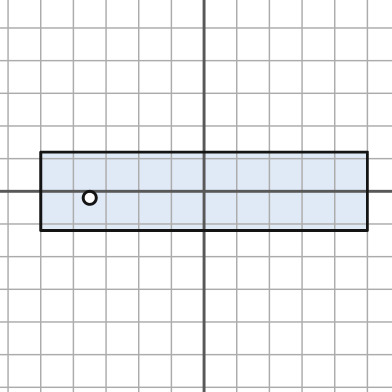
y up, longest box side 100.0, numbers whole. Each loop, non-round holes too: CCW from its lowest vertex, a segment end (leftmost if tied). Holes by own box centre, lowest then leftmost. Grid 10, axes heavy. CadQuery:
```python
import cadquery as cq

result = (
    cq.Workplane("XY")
    .moveTo(-50.0, -12.0)
    .lineTo(50.0, -12.0)
    .lineTo(50.0, 12.0)
    .lineTo(-50.0, 12.0)
    .close()
    .moveTo(-35.0, -2.0)
    .circle(2.0)
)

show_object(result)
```